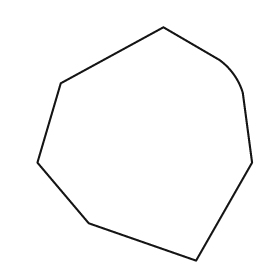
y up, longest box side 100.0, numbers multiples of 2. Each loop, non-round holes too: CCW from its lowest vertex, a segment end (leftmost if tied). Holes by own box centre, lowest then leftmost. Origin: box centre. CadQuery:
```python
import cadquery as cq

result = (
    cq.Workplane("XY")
    .moveTo(22.0, -50.0)
    .lineTo(46.0, -8.0)
    .lineTo(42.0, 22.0)
    .threePointArc((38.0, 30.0), (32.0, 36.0))
    .lineTo(8.0, 50.0)
    .lineTo(-36.0, 26.0)
    .lineTo(-46.0, -8.0)
    .lineTo(-24.0, -34.0)
    .close()
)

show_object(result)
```